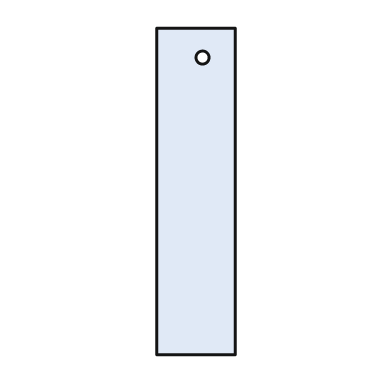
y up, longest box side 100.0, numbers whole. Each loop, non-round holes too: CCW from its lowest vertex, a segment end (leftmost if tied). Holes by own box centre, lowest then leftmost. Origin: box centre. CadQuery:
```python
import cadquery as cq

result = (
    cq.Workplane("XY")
    .moveTo(-12.0, -50.0)
    .lineTo(12.0, -50.0)
    .lineTo(12.0, 50.0)
    .lineTo(-12.0, 50.0)
    .close()
    .moveTo(2.0, 41.0)
    .circle(2.0)
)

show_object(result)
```